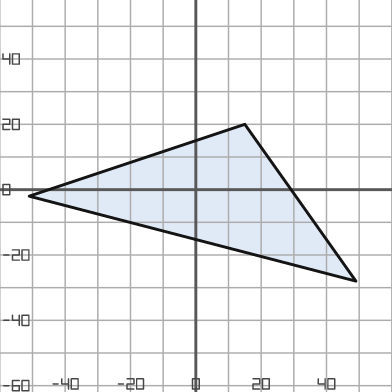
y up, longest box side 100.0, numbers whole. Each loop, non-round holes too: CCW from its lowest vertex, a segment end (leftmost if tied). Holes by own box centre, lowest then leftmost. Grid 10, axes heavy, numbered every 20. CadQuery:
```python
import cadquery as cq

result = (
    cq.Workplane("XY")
    .moveTo(49.0, -28.0)
    .lineTo(15.0, 20.0)
    .lineTo(-51.0, -2.0)
    .close()
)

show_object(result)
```